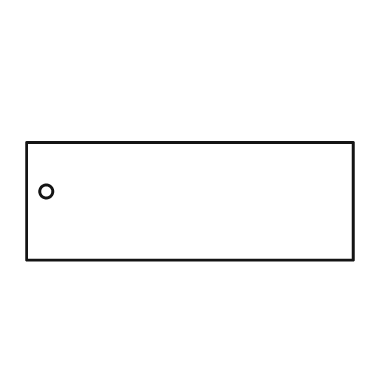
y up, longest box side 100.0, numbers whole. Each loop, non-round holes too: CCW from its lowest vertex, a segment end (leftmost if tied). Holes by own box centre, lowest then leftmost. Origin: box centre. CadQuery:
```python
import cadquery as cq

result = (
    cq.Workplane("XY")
    .moveTo(-50.0, -18.0)
    .lineTo(50.0, -18.0)
    .lineTo(50.0, 18.0)
    .lineTo(-50.0, 18.0)
    .close()
    .moveTo(-44.0, 3.0)
    .circle(2.0)
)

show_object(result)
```